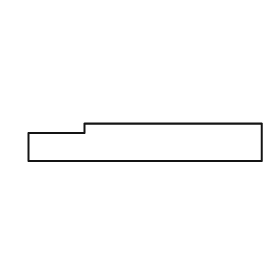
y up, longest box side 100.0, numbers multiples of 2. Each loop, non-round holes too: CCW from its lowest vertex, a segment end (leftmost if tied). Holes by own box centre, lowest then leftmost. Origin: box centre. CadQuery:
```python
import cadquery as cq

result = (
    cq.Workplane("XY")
    .moveTo(-50.0, -8.0)
    .lineTo(50.0, -8.0)
    .lineTo(50.0, 8.0)
    .lineTo(-26.0, 8.0)
    .lineTo(-26.0, 4.0)
    .lineTo(-50.0, 4.0)
    .close()
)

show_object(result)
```